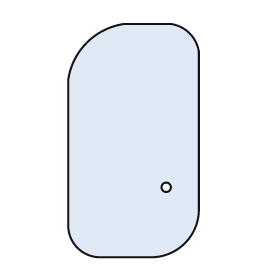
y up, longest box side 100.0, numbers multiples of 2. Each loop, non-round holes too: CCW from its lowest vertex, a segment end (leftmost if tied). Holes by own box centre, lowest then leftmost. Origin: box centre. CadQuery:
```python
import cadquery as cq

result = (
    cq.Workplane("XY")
    .moveTo(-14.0, -50.0)
    .lineTo(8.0, -50.0)
    .threePointArc((22.0, -44.0), (28.0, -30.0))
    .lineTo(28.0, 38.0)
    .threePointArc((24.0, 46.0), (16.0, 50.0))
    .lineTo(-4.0, 50.0)
    .threePointArc((-20.0, 42.0), (-28.0, 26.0))
    .lineTo(-28.0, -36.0)
    .threePointArc((-24.0, -46.0), (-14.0, -50.0))
    .close()
    .moveTo(14.0, -20.0)
    .circle(2.0)
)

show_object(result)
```